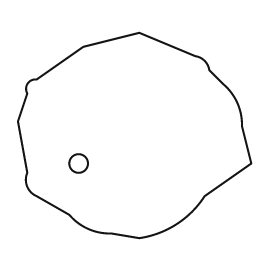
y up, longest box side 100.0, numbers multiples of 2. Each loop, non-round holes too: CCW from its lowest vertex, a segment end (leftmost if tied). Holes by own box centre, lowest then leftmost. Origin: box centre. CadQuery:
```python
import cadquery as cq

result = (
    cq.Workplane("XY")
    .moveTo(2.0, -44.0)
    .threePointArc((18.0, -38.0), (30.0, -26.0))
    .lineTo(50.0, -12.0)
    .lineTo(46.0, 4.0)
    .threePointArc((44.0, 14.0), (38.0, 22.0))
    .lineTo(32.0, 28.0)
    .threePointArc((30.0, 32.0), (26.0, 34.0))
    .lineTo(2.0, 44.0)
    .lineTo(-22.0, 38.0)
    .lineTo(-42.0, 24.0)
    .threePointArc((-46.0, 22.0), (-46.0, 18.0))
    .lineTo(-50.0, 6.0)
    .lineTo(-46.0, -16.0)
    .threePointArc((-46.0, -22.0), (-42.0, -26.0))
    .lineTo(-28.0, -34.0)
    .threePointArc((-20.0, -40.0), (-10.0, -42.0))
    .close()
    .moveTo(-24.0, -12.0)
    .circle(4.0)
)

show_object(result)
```